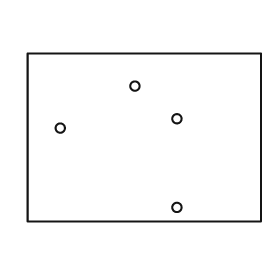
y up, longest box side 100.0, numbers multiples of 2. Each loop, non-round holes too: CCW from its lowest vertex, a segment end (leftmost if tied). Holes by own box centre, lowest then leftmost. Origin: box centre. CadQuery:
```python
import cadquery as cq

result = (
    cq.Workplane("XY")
    .moveTo(-50.0, -36.0)
    .lineTo(50.0, -36.0)
    .lineTo(50.0, 36.0)
    .lineTo(-50.0, 36.0)
    .close()
    .moveTo(14.0, -30.0)
    .circle(2.0)
    .moveTo(-36.0, 4.0)
    .circle(2.0)
    .moveTo(14.0, 8.0)
    .circle(2.0)
    .moveTo(-4.0, 22.0)
    .circle(2.0)
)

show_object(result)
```